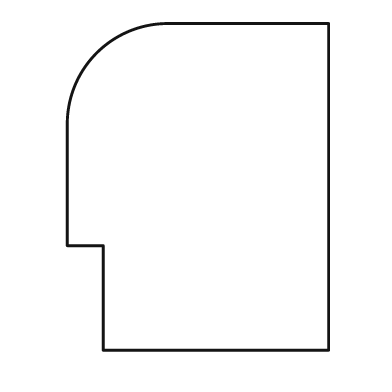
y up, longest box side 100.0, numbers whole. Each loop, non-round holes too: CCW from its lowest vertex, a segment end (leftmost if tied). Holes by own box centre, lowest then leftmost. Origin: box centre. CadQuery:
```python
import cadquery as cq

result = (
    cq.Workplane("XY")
    .moveTo(-29.0, -50.0)
    .lineTo(40.0, -50.0)
    .lineTo(40.0, 50.0)
    .lineTo(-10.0, 50.0)
    .threePointArc((-31.0, 41.0), (-40.0, 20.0))
    .lineTo(-40.0, -18.0)
    .lineTo(-29.0, -18.0)
    .close()
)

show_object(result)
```